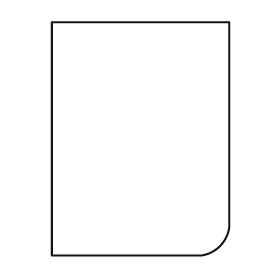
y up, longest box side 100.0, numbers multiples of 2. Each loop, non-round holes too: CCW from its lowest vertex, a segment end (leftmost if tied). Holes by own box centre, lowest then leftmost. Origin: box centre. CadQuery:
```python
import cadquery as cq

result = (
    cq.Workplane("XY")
    .moveTo(-38.0, -50.0)
    .lineTo(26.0, -50.0)
    .threePointArc((34.0, -46.0), (38.0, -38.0))
    .lineTo(38.0, 50.0)
    .lineTo(-38.0, 50.0)
    .close()
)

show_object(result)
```